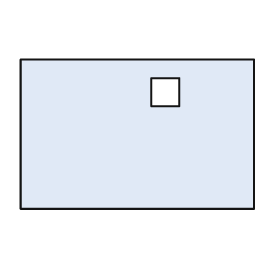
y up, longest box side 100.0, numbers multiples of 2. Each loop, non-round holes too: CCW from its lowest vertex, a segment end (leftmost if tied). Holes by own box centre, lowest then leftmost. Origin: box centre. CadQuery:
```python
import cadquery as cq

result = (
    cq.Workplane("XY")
    .moveTo(-50.0, -32.0)
    .lineTo(50.0, -32.0)
    .lineTo(50.0, 32.0)
    .lineTo(-50.0, 32.0)
    .close()
    .moveTo(6.0, 12.0)
    .lineTo(18.0, 12.0)
    .lineTo(18.0, 24.0)
    .lineTo(6.0, 24.0)
    .close()
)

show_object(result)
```